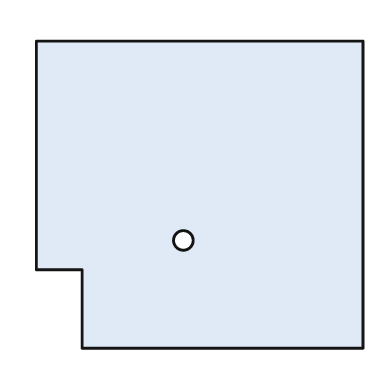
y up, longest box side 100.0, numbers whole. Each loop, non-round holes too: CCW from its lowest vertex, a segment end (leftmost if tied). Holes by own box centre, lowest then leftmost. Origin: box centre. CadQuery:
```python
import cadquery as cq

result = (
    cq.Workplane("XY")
    .moveTo(-36.0, -47.0)
    .lineTo(50.0, -47.0)
    .lineTo(50.0, 47.0)
    .lineTo(-50.0, 47.0)
    .lineTo(-50.0, -23.0)
    .lineTo(-36.0, -23.0)
    .close()
    .moveTo(-5.0, -14.0)
    .circle(3.0)
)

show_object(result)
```